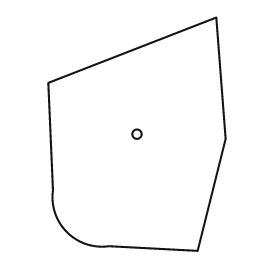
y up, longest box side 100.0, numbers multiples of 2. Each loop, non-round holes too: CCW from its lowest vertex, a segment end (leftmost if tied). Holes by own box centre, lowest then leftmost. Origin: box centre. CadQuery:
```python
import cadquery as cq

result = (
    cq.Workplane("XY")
    .moveTo(26.0, -50.0)
    .lineTo(38.0, -2.0)
    .lineTo(34.0, 50.0)
    .lineTo(-38.0, 22.0)
    .lineTo(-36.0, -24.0)
    .threePointArc((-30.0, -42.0), (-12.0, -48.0))
    .close()
    .moveTo(0.0, 0.0)
    .circle(2.0)
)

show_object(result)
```